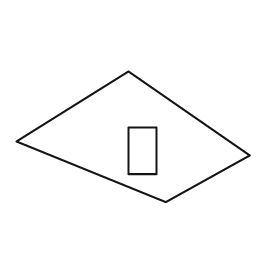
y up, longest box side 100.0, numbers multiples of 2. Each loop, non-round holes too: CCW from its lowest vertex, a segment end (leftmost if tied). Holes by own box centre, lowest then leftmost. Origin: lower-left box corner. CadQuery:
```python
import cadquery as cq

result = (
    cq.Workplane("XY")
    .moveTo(64.0, 0.0)
    .lineTo(100.0, 20.0)
    .lineTo(48.0, 56.0)
    .lineTo(0.0, 26.0)
    .close()
    .moveTo(48.0, 12.0)
    .lineTo(60.0, 12.0)
    .lineTo(60.0, 32.0)
    .lineTo(48.0, 32.0)
    .close()
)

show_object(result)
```